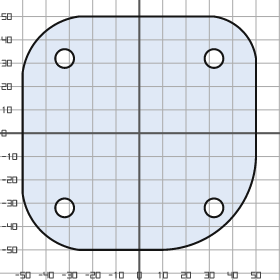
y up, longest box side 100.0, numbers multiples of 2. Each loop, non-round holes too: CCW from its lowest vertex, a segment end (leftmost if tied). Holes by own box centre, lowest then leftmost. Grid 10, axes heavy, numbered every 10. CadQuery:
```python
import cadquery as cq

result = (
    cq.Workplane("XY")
    .moveTo(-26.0, -50.0)
    .lineTo(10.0, -50.0)
    .threePointArc((38.0, -38.0), (50.0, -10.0))
    .lineTo(50.0, 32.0)
    .threePointArc((44.0, 44.0), (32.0, 50.0))
    .lineTo(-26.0, 50.0)
    .threePointArc((-42.0, 42.0), (-50.0, 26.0))
    .lineTo(-50.0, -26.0)
    .threePointArc((-42.0, -42.0), (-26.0, -50.0))
    .close()
    .moveTo(-32.0, -32.0)
    .circle(4.0)
    .moveTo(32.0, -32.0)
    .circle(4.0)
    .moveTo(-32.0, 32.0)
    .circle(4.0)
    .moveTo(32.0, 32.0)
    .circle(4.0)
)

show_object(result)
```